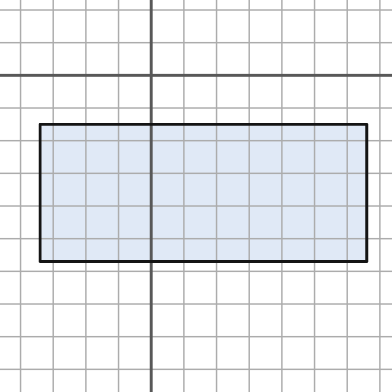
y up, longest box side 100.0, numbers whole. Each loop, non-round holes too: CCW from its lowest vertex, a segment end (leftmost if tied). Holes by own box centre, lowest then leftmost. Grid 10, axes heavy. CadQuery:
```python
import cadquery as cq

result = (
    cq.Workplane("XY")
    .moveTo(-34.0, -57.0)
    .lineTo(66.0, -57.0)
    .lineTo(66.0, -15.0)
    .lineTo(-34.0, -15.0)
    .close()
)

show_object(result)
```